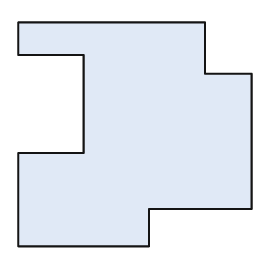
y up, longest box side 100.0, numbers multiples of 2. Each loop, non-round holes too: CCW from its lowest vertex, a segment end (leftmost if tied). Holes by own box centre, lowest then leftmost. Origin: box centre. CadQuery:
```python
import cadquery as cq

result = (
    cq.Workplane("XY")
    .moveTo(-50.0, -48.0)
    .lineTo(6.0, -48.0)
    .lineTo(6.0, -32.0)
    .lineTo(50.0, -32.0)
    .lineTo(50.0, 26.0)
    .lineTo(30.0, 26.0)
    .lineTo(30.0, 48.0)
    .lineTo(-50.0, 48.0)
    .lineTo(-50.0, 34.0)
    .lineTo(-22.0, 34.0)
    .lineTo(-22.0, -8.0)
    .lineTo(-50.0, -8.0)
    .close()
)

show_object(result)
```